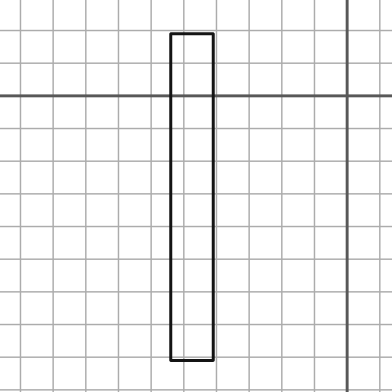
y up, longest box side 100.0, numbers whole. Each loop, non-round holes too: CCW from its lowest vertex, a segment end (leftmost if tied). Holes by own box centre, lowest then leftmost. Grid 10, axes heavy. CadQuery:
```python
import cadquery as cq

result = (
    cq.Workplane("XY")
    .moveTo(-54.0, -81.0)
    .lineTo(-41.0, -81.0)
    .lineTo(-41.0, 19.0)
    .lineTo(-54.0, 19.0)
    .close()
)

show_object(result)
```